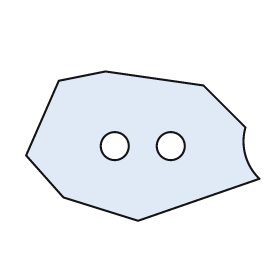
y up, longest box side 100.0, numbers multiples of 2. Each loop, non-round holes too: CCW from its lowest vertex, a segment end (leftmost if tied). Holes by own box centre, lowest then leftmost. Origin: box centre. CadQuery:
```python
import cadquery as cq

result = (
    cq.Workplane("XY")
    .moveTo(-2.0, -32.0)
    .lineTo(50.0, -14.0)
    .threePointArc((44.0, -4.0), (44.0, 8.0))
    .lineTo(26.0, 26.0)
    .lineTo(-16.0, 32.0)
    .lineTo(-36.0, 28.0)
    .lineTo(-50.0, -4.0)
    .lineTo(-34.0, -22.0)
    .close()
    .moveTo(-12.0, 0.0)
    .circle(6.0)
    .moveTo(12.0, 0.0)
    .circle(6.0)
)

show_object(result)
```